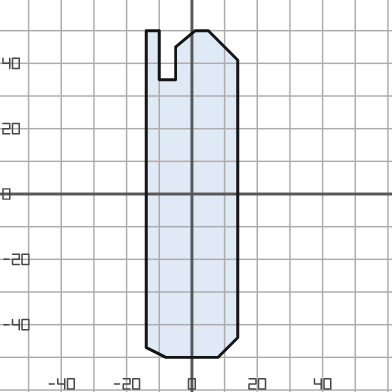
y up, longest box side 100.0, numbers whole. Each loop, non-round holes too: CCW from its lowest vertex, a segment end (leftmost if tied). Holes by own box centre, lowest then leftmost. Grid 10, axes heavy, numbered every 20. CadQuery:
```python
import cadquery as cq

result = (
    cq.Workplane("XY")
    .moveTo(-8.0, -50.0)
    .lineTo(8.0, -50.0)
    .lineTo(14.0, -44.0)
    .lineTo(14.0, 41.0)
    .lineTo(5.0, 50.0)
    .lineTo(1.0, 50.0)
    .lineTo(-5.0, 45.0)
    .lineTo(-5.0, 35.0)
    .lineTo(-10.0, 35.0)
    .lineTo(-10.0, 50.0)
    .lineTo(-14.0, 50.0)
    .lineTo(-14.0, -47.0)
    .close()
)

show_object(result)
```